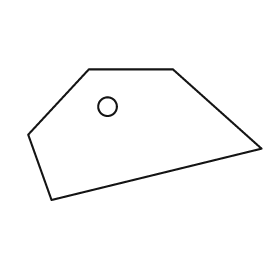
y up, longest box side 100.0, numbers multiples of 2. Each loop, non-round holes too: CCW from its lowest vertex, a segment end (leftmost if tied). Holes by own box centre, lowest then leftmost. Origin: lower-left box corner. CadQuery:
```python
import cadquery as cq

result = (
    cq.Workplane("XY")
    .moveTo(10.0, 0.0)
    .lineTo(100.0, 22.0)
    .lineTo(62.0, 56.0)
    .lineTo(26.0, 56.0)
    .lineTo(0.0, 28.0)
    .close()
    .moveTo(34.0, 40.0)
    .circle(4.0)
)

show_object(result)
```